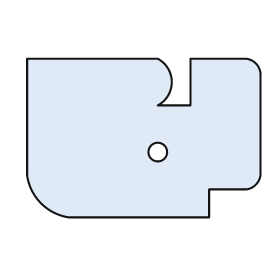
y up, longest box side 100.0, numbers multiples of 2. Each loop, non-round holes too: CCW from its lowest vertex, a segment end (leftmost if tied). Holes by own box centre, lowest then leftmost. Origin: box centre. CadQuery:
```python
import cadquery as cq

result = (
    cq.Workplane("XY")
    .moveTo(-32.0, -34.0)
    .lineTo(28.0, -34.0)
    .lineTo(28.0, -22.0)
    .lineTo(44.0, -22.0)
    .threePointArc((48.0, -20.0), (50.0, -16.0))
    .lineTo(50.0, 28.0)
    .threePointArc((48.0, 32.0), (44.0, 34.0))
    .lineTo(20.0, 34.0)
    .lineTo(20.0, 14.0)
    .lineTo(6.0, 14.0)
    .threePointArc((12.0, 24.0), (6.0, 34.0))
    .lineTo(-50.0, 34.0)
    .lineTo(-50.0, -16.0)
    .threePointArc((-44.0, -28.0), (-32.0, -34.0))
    .close()
    .moveTo(6.0, -6.0)
    .circle(4.0)
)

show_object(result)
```